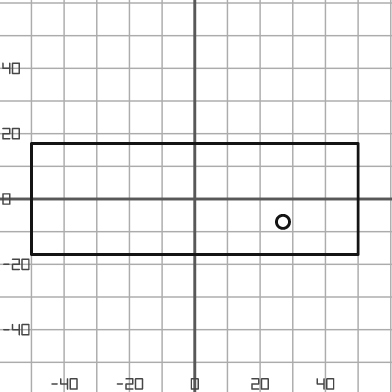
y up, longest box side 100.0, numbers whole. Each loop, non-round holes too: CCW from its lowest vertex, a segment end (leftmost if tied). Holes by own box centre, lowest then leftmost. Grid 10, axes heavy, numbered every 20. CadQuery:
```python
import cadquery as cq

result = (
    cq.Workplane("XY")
    .moveTo(-50.0, -17.0)
    .lineTo(50.0, -17.0)
    .lineTo(50.0, 17.0)
    .lineTo(-50.0, 17.0)
    .close()
    .moveTo(27.0, -7.0)
    .circle(2.0)
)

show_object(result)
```